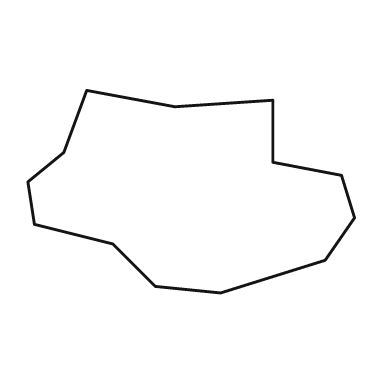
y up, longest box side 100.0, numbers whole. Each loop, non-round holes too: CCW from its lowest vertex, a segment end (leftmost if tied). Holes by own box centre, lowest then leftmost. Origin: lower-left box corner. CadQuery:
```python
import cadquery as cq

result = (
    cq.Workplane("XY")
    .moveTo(59.0, 0.0)
    .lineTo(91.0, 10.0)
    .lineTo(100.0, 23.0)
    .lineTo(96.0, 36.0)
    .lineTo(75.0, 40.0)
    .lineTo(75.0, 59.0)
    .lineTo(45.0, 57.0)
    .lineTo(18.0, 62.0)
    .lineTo(11.0, 43.0)
    .lineTo(0.0, 34.0)
    .lineTo(2.0, 21.0)
    .lineTo(26.0, 15.0)
    .lineTo(39.0, 2.0)
    .close()
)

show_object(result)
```